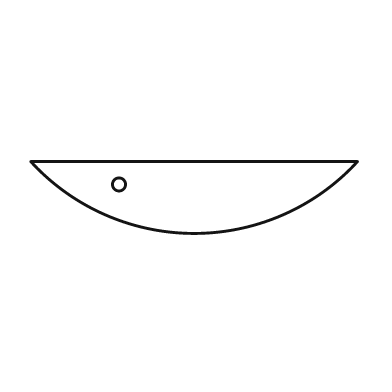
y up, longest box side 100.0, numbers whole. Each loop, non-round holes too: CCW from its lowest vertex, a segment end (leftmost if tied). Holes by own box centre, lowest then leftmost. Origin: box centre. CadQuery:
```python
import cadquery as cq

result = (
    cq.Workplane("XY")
    .moveTo(-50.0, 11.0)
    .threePointArc((0.0, -11.0), (50.0, 11.0))
    .close()
    .moveTo(-23.0, 4.0)
    .circle(2.0)
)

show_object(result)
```